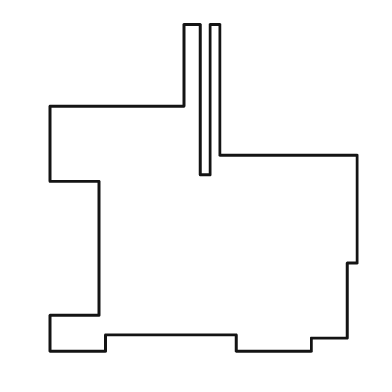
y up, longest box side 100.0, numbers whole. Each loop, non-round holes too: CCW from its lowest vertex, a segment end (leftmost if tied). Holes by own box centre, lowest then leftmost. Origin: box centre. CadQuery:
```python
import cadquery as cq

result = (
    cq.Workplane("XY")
    .moveTo(-47.0, -50.0)
    .lineTo(-30.0, -50.0)
    .lineTo(-30.0, -45.0)
    .lineTo(10.0, -45.0)
    .lineTo(10.0, -50.0)
    .lineTo(33.0, -50.0)
    .lineTo(33.0, -46.0)
    .lineTo(44.0, -46.0)
    .lineTo(44.0, -23.0)
    .lineTo(47.0, -23.0)
    .lineTo(47.0, 10.0)
    .lineTo(5.0, 10.0)
    .lineTo(5.0, 50.0)
    .lineTo(2.0, 50.0)
    .lineTo(2.0, 4.0)
    .lineTo(-1.0, 4.0)
    .lineTo(-1.0, 50.0)
    .lineTo(-6.0, 50.0)
    .lineTo(-6.0, 25.0)
    .lineTo(-47.0, 25.0)
    .lineTo(-47.0, 2.0)
    .lineTo(-32.0, 2.0)
    .lineTo(-32.0, -39.0)
    .lineTo(-47.0, -39.0)
    .close()
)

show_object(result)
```